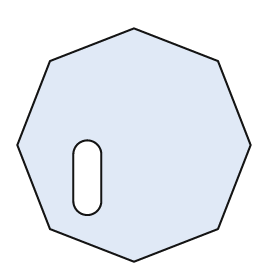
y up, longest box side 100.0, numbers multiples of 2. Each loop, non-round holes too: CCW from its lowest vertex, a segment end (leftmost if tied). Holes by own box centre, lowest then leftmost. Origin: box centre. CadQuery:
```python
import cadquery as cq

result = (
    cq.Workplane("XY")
    .moveTo(0.0, -50.0)
    .lineTo(36.0, -36.0)
    .lineTo(50.0, 0.0)
    .lineTo(36.0, 36.0)
    .lineTo(0.0, 50.0)
    .lineTo(-36.0, 36.0)
    .lineTo(-50.0, 0.0)
    .lineTo(-36.0, -36.0)
    .close()
    .moveTo(-26.0, -24.0)
    .threePointArc((-20.0, -30.0), (-14.0, -24.0))
    .lineTo(-14.0, -4.0)
    .threePointArc((-20.0, 2.0), (-26.0, -4.0))
    .close()
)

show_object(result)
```